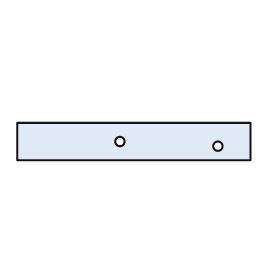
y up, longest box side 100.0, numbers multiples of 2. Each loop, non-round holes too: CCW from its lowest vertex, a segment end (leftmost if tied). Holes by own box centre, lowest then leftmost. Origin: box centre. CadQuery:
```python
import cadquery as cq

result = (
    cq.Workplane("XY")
    .moveTo(-50.0, -8.0)
    .lineTo(50.0, -8.0)
    .lineTo(50.0, 8.0)
    .lineTo(-50.0, 8.0)
    .close()
    .moveTo(36.0, -2.0)
    .circle(2.0)
    .moveTo(-6.0, 0.0)
    .circle(2.0)
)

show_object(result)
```